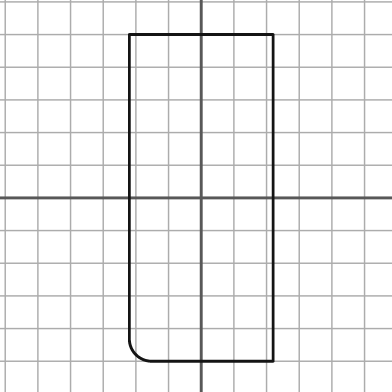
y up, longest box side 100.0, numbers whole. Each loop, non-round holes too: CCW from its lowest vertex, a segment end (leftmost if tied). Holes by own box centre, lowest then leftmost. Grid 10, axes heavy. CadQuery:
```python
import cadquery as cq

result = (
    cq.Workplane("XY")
    .moveTo(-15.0, -50.0)
    .lineTo(22.0, -50.0)
    .lineTo(22.0, 50.0)
    .lineTo(-22.0, 50.0)
    .lineTo(-22.0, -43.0)
    .threePointArc((-20.0, -48.0), (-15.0, -50.0))
    .close()
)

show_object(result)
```